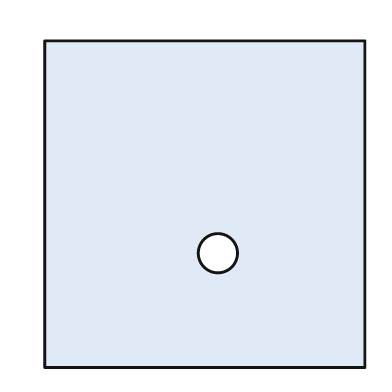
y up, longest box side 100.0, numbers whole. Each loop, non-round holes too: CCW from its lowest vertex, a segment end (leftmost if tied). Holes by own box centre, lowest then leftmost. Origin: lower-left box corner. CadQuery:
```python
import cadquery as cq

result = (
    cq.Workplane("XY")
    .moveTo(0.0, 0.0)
    .lineTo(98.0, 0.0)
    .lineTo(98.0, 100.0)
    .lineTo(0.0, 100.0)
    .close()
    .moveTo(53.0, 35.0)
    .circle(6.0)
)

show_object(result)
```